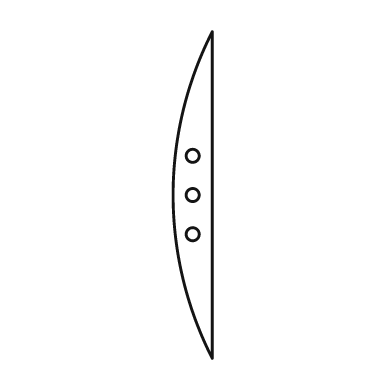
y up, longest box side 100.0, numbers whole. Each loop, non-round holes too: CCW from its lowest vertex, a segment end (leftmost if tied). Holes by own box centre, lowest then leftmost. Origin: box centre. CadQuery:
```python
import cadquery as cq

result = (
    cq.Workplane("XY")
    .moveTo(6.0, -50.0)
    .lineTo(6.0, 50.0)
    .threePointArc((-6.0, 0.0), (6.0, -50.0))
    .close()
    .moveTo(0.0, -12.0)
    .circle(2.0)
    .moveTo(0.0, 0.0)
    .circle(2.0)
    .moveTo(0.0, 12.0)
    .circle(2.0)
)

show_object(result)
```